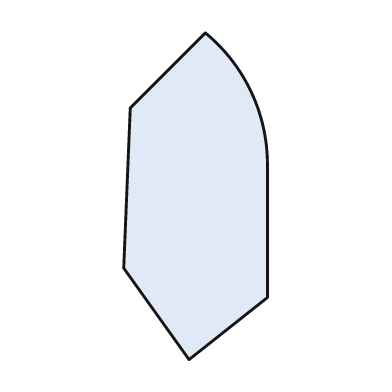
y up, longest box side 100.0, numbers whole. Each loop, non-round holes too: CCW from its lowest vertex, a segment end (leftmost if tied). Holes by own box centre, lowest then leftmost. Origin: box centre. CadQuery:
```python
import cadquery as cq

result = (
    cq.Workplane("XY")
    .moveTo(-2.0, -50.0)
    .lineTo(22.0, -31.0)
    .lineTo(22.0, 10.0)
    .threePointArc((17.0, 32.0), (3.0, 50.0))
    .lineTo(-20.0, 27.0)
    .lineTo(-22.0, -22.0)
    .close()
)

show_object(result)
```